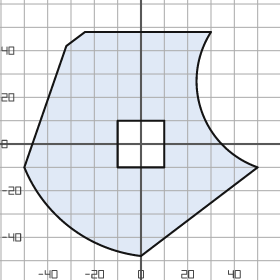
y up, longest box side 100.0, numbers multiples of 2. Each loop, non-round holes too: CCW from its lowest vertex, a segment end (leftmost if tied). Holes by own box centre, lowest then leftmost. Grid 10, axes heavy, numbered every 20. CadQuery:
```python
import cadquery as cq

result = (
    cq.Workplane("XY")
    .moveTo(0.0, -48.0)
    .lineTo(50.0, -10.0)
    .threePointArc((26.0, 14.0), (30.0, 48.0))
    .lineTo(-24.0, 48.0)
    .lineTo(-32.0, 42.0)
    .lineTo(-50.0, -10.0)
    .threePointArc((-30.0, -36.0), (0.0, -48.0))
    .close()
    .moveTo(-10.0, -10.0)
    .lineTo(10.0, -10.0)
    .lineTo(10.0, 10.0)
    .lineTo(-10.0, 10.0)
    .close()
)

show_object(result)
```